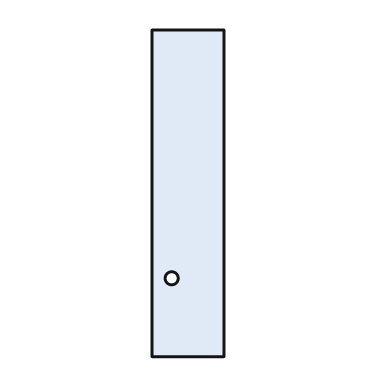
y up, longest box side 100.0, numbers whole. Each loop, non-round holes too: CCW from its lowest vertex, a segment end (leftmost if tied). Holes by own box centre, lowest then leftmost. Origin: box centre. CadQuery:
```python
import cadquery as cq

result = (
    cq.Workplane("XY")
    .moveTo(-11.0, -50.0)
    .lineTo(11.0, -50.0)
    .lineTo(11.0, 50.0)
    .lineTo(-11.0, 50.0)
    .close()
    .moveTo(-5.0, -26.0)
    .circle(2.0)
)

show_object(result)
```